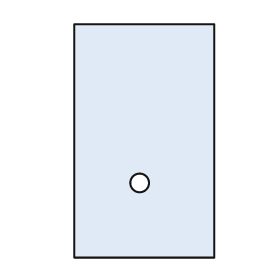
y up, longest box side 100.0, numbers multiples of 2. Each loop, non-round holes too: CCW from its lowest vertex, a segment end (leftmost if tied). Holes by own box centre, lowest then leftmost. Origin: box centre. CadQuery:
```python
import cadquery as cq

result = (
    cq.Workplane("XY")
    .moveTo(-30.0, -50.0)
    .lineTo(30.0, -50.0)
    .lineTo(30.0, 50.0)
    .lineTo(-30.0, 50.0)
    .close()
    .moveTo(-2.0, -18.0)
    .circle(4.0)
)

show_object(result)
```